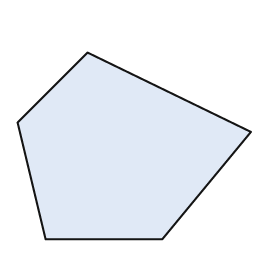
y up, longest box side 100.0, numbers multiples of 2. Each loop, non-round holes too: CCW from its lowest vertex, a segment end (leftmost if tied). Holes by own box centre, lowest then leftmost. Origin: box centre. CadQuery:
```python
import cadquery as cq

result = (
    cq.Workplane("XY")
    .moveTo(-38.0, -40.0)
    .lineTo(12.0, -40.0)
    .lineTo(50.0, 6.0)
    .lineTo(-20.0, 40.0)
    .lineTo(-50.0, 10.0)
    .close()
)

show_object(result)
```